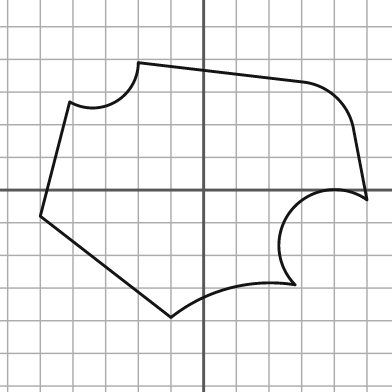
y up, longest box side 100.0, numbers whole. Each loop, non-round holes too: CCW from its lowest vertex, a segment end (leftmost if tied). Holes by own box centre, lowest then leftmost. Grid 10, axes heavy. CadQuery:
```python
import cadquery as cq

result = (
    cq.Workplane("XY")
    .moveTo(-10.0, -39.0)
    .threePointArc((8.0, -30.0), (28.0, -29.0))
    .threePointArc((27.0, -6.0), (50.0, -3.0))
    .lineTo(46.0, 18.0)
    .threePointArc((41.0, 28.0), (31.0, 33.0))
    .lineTo(-20.0, 39.0)
    .threePointArc((-27.0, 27.0), (-41.0, 27.0))
    .lineTo(-50.0, -8.0)
    .close()
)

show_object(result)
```